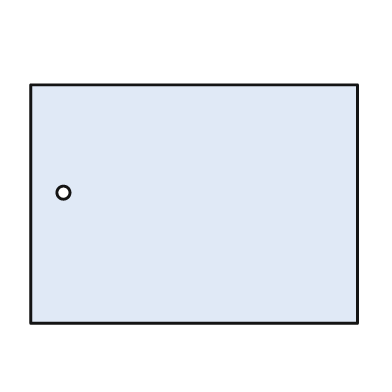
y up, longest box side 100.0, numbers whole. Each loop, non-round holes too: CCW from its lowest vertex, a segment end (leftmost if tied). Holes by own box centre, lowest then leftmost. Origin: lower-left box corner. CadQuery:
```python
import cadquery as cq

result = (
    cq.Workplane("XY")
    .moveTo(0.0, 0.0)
    .lineTo(100.0, 0.0)
    .lineTo(100.0, 73.0)
    .lineTo(0.0, 73.0)
    .close()
    .moveTo(10.0, 40.0)
    .circle(2.0)
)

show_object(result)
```